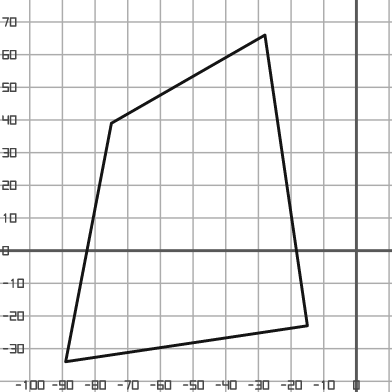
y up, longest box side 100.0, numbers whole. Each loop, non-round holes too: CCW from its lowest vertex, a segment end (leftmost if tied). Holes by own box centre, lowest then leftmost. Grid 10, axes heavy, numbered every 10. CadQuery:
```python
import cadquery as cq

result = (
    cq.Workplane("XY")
    .moveTo(-89.0, -34.0)
    .lineTo(-15.0, -23.0)
    .lineTo(-28.0, 66.0)
    .lineTo(-75.0, 39.0)
    .close()
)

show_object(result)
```